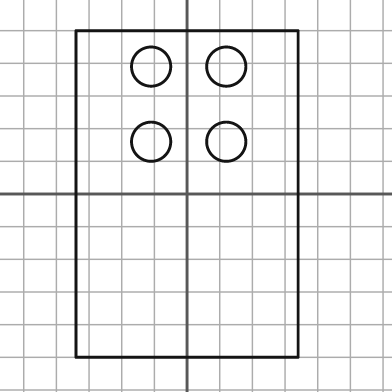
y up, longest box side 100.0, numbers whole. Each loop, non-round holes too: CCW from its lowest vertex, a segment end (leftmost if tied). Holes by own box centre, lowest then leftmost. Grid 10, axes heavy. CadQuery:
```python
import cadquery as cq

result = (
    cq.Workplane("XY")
    .moveTo(-34.0, -50.0)
    .lineTo(34.0, -50.0)
    .lineTo(34.0, 50.0)
    .lineTo(-34.0, 50.0)
    .close()
    .moveTo(-11.0, 16.0)
    .circle(6.0)
    .moveTo(12.0, 16.0)
    .circle(6.0)
    .moveTo(-11.0, 39.0)
    .circle(6.0)
    .moveTo(12.0, 39.0)
    .circle(6.0)
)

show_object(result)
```